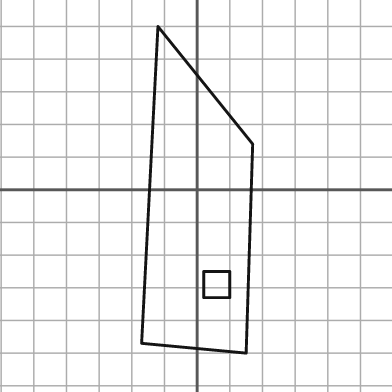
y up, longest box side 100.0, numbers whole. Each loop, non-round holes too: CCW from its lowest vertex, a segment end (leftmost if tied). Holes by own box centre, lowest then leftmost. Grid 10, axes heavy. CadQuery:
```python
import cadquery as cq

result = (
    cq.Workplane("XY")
    .moveTo(15.0, -50.0)
    .lineTo(17.0, 14.0)
    .lineTo(-12.0, 50.0)
    .lineTo(-17.0, -47.0)
    .close()
    .moveTo(2.0, -33.0)
    .lineTo(10.0, -33.0)
    .lineTo(10.0, -25.0)
    .lineTo(2.0, -25.0)
    .close()
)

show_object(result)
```